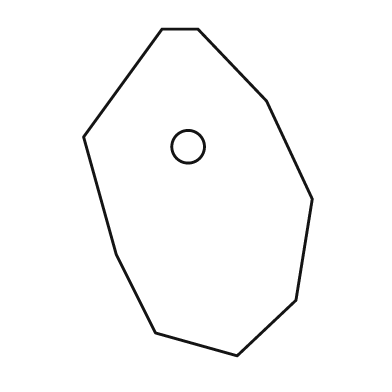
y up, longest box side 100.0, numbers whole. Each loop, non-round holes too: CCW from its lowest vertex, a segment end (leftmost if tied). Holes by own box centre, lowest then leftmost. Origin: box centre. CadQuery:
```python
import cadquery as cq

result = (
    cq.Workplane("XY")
    .moveTo(12.0, -50.0)
    .lineTo(30.0, -33.0)
    .lineTo(35.0, -2.0)
    .lineTo(21.0, 28.0)
    .lineTo(0.0, 50.0)
    .lineTo(-11.0, 50.0)
    .lineTo(-35.0, 17.0)
    .lineTo(-25.0, -19.0)
    .lineTo(-13.0, -43.0)
    .close()
    .moveTo(-3.0, 14.0)
    .circle(5.0)
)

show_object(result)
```